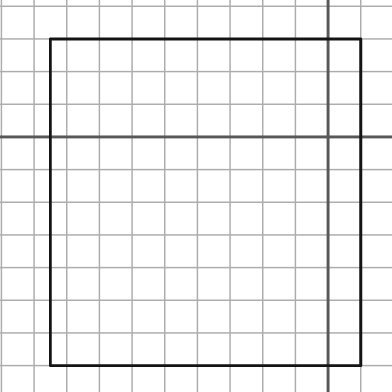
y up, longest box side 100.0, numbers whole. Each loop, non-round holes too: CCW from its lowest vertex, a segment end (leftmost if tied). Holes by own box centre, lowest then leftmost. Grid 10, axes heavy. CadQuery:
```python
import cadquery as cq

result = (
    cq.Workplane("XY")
    .moveTo(-85.0, -70.0)
    .lineTo(10.0, -70.0)
    .lineTo(10.0, 30.0)
    .lineTo(-85.0, 30.0)
    .close()
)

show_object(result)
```